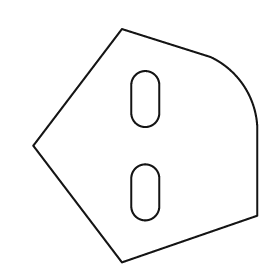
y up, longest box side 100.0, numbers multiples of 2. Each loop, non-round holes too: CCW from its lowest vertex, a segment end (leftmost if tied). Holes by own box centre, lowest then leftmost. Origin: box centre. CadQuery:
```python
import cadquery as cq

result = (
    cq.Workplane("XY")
    .moveTo(-10.0, -50.0)
    .lineTo(48.0, -30.0)
    .lineTo(48.0, 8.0)
    .threePointArc((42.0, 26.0), (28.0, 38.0))
    .lineTo(-10.0, 50.0)
    .lineTo(-48.0, 0.0)
    .close()
    .moveTo(-6.0, -26.0)
    .threePointArc((0.0, -32.0), (6.0, -26.0))
    .lineTo(6.0, -14.0)
    .threePointArc((0.0, -8.0), (-6.0, -14.0))
    .close()
    .moveTo(-6.0, 14.0)
    .threePointArc((0.0, 8.0), (6.0, 14.0))
    .lineTo(6.0, 26.0)
    .threePointArc((0.0, 32.0), (-6.0, 26.0))
    .close()
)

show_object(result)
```